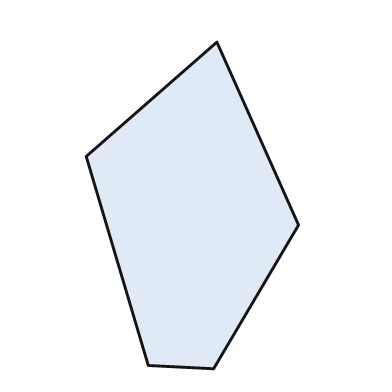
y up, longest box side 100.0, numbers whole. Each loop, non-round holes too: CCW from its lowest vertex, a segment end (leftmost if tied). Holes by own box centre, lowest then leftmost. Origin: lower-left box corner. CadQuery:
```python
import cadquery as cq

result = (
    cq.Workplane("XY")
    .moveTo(39.0, 0.0)
    .lineTo(65.0, 44.0)
    .lineTo(40.0, 100.0)
    .lineTo(0.0, 65.0)
    .lineTo(19.0, 1.0)
    .close()
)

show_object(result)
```